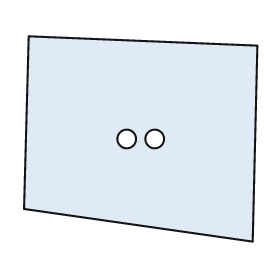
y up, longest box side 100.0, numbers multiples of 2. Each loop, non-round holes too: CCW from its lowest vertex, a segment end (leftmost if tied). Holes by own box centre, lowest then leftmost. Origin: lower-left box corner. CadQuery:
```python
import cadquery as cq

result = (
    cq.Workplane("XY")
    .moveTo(98.0, 0.0)
    .lineTo(100.0, 84.0)
    .lineTo(2.0, 88.0)
    .lineTo(0.0, 14.0)
    .close()
    .moveTo(44.0, 44.0)
    .circle(4.0)
    .moveTo(56.0, 44.0)
    .circle(4.0)
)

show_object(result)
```